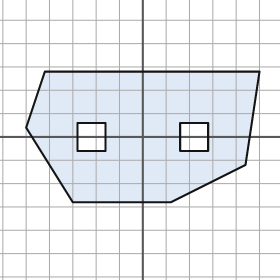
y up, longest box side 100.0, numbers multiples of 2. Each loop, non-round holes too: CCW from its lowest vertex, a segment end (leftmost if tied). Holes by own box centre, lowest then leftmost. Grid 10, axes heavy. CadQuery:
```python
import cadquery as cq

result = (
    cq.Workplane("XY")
    .moveTo(-30.0, -28.0)
    .lineTo(12.0, -28.0)
    .lineTo(44.0, -12.0)
    .lineTo(50.0, 28.0)
    .lineTo(-42.0, 28.0)
    .lineTo(-50.0, 4.0)
    .close()
    .moveTo(-28.0, -6.0)
    .lineTo(-16.0, -6.0)
    .lineTo(-16.0, 6.0)
    .lineTo(-28.0, 6.0)
    .close()
    .moveTo(16.0, -6.0)
    .lineTo(28.0, -6.0)
    .lineTo(28.0, 6.0)
    .lineTo(16.0, 6.0)
    .close()
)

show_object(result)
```